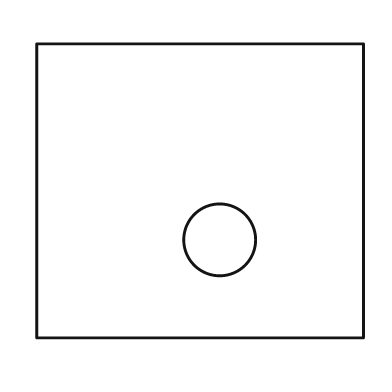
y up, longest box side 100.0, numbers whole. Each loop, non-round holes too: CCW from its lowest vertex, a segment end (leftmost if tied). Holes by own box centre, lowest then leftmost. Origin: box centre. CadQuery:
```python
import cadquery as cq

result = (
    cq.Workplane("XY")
    .moveTo(-50.0, -45.0)
    .lineTo(50.0, -45.0)
    .lineTo(50.0, 45.0)
    .lineTo(-50.0, 45.0)
    .close()
    .moveTo(6.0, -15.0)
    .circle(11.0)
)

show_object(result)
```